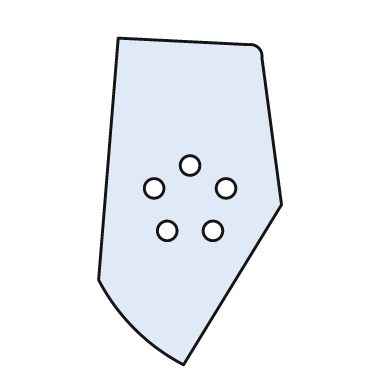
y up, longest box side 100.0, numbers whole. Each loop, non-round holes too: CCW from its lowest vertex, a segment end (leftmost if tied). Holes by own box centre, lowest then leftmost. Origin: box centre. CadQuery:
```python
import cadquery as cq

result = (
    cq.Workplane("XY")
    .moveTo(-2.0, -50.0)
    .lineTo(28.0, -1.0)
    .lineTo(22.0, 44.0)
    .threePointArc((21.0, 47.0), (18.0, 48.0))
    .lineTo(-22.0, 50.0)
    .lineTo(-28.0, -24.0)
    .threePointArc((-17.0, -39.0), (-2.0, -50.0))
    .close()
    .moveTo(-7.0, -9.0)
    .circle(3.0)
    .moveTo(7.0, -9.0)
    .circle(3.0)
    .moveTo(-11.0, 4.0)
    .circle(3.0)
    .moveTo(11.0, 4.0)
    .circle(3.0)
    .moveTo(0.0, 11.0)
    .circle(3.0)
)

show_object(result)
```